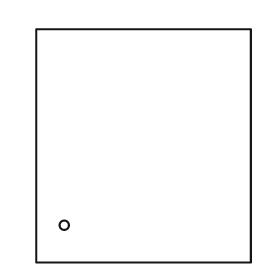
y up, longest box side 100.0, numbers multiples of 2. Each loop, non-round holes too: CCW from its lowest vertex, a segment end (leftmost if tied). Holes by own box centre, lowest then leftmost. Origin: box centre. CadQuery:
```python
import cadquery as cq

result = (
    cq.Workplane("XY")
    .moveTo(-46.0, -50.0)
    .lineTo(46.0, -50.0)
    .lineTo(46.0, 50.0)
    .lineTo(-46.0, 50.0)
    .close()
    .moveTo(-34.0, -34.0)
    .circle(2.0)
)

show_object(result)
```